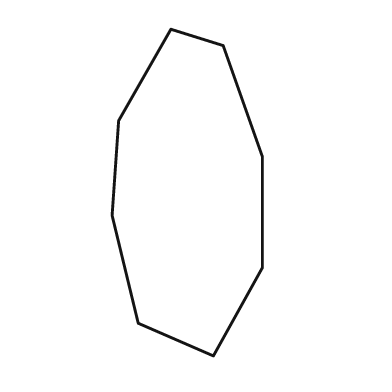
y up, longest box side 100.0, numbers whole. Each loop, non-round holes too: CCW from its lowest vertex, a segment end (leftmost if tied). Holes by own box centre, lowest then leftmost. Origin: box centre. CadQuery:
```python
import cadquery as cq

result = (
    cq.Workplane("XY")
    .moveTo(8.0, -50.0)
    .lineTo(23.0, -23.0)
    .lineTo(23.0, 11.0)
    .lineTo(11.0, 45.0)
    .lineTo(-5.0, 50.0)
    .lineTo(-21.0, 22.0)
    .lineTo(-23.0, -7.0)
    .lineTo(-15.0, -40.0)
    .close()
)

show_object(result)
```